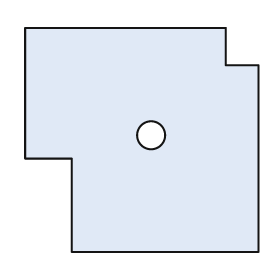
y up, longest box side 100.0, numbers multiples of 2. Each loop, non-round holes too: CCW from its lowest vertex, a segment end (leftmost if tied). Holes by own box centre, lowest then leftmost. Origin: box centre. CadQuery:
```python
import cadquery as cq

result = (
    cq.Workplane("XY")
    .moveTo(-30.0, -48.0)
    .lineTo(50.0, -48.0)
    .lineTo(50.0, 32.0)
    .lineTo(36.0, 32.0)
    .lineTo(36.0, 48.0)
    .lineTo(-50.0, 48.0)
    .lineTo(-50.0, -8.0)
    .lineTo(-30.0, -8.0)
    .close()
    .moveTo(4.0, 2.0)
    .circle(6.0)
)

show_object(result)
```